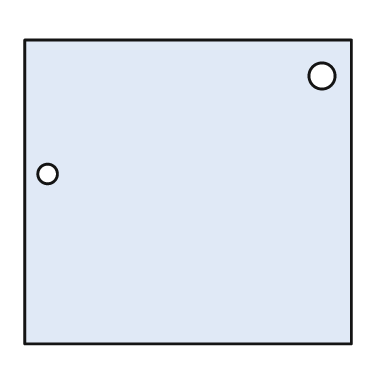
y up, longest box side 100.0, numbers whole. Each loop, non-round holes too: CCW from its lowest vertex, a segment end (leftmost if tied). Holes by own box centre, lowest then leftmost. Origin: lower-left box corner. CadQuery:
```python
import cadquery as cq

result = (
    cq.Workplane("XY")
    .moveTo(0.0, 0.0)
    .lineTo(100.0, 0.0)
    .lineTo(100.0, 93.0)
    .lineTo(0.0, 93.0)
    .close()
    .moveTo(7.0, 52.0)
    .circle(3.0)
    .moveTo(91.0, 82.0)
    .circle(4.0)
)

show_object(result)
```